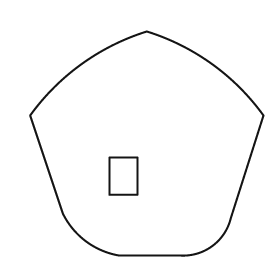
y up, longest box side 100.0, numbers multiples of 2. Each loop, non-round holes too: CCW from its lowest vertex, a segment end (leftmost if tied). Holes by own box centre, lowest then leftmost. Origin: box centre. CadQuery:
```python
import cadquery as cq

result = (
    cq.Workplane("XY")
    .moveTo(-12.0, -48.0)
    .lineTo(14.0, -48.0)
    .threePointArc((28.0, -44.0), (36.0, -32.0))
    .lineTo(50.0, 12.0)
    .threePointArc((28.0, 34.0), (0.0, 48.0))
    .threePointArc((-28.0, 34.0), (-50.0, 12.0))
    .lineTo(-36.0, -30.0)
    .threePointArc((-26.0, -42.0), (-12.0, -48.0))
    .close()
    .moveTo(-16.0, -22.0)
    .lineTo(-4.0, -22.0)
    .lineTo(-4.0, -6.0)
    .lineTo(-16.0, -6.0)
    .close()
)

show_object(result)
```